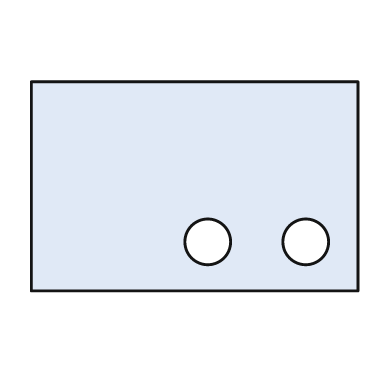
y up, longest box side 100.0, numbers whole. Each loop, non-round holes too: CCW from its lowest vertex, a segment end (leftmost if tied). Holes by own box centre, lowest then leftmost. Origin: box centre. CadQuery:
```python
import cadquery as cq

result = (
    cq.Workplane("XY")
    .moveTo(-50.0, -32.0)
    .lineTo(50.0, -32.0)
    .lineTo(50.0, 32.0)
    .lineTo(-50.0, 32.0)
    .close()
    .moveTo(4.0, -17.0)
    .circle(7.0)
    .moveTo(34.0, -17.0)
    .circle(7.0)
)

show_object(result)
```